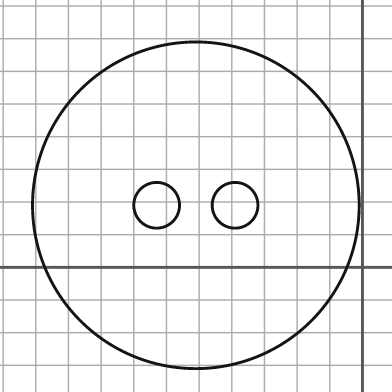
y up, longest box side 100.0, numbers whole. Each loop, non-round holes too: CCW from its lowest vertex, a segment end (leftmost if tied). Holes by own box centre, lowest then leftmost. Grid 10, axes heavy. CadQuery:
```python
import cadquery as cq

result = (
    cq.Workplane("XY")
    .moveTo(-51.0, 19.0)
    .circle(50.0)
    .moveTo(-63.0, 19.0)
    .circle(7.0)
    .moveTo(-39.0, 19.0)
    .circle(7.0)
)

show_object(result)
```